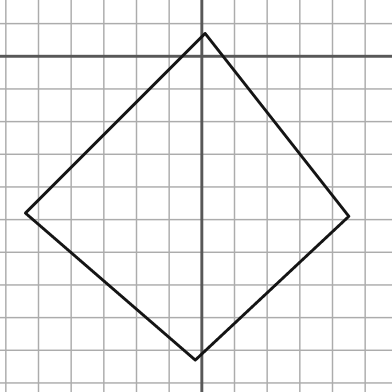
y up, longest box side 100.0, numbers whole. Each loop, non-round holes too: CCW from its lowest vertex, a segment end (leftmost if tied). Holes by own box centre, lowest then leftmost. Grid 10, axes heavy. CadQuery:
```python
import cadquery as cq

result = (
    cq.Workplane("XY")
    .moveTo(-2.0, -93.0)
    .lineTo(45.0, -49.0)
    .lineTo(1.0, 7.0)
    .lineTo(-54.0, -48.0)
    .close()
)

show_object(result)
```